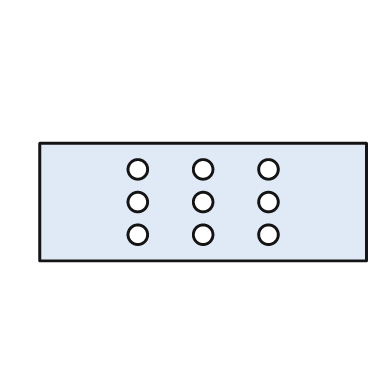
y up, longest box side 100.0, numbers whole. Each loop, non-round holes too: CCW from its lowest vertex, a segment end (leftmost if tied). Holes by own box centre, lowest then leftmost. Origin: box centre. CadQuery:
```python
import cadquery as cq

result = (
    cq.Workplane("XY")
    .moveTo(-50.0, -18.0)
    .lineTo(50.0, -18.0)
    .lineTo(50.0, 18.0)
    .lineTo(-50.0, 18.0)
    .close()
    .moveTo(-20.0, -10.0)
    .circle(3.0)
    .moveTo(0.0, -10.0)
    .circle(3.0)
    .moveTo(20.0, -10.0)
    .circle(3.0)
    .moveTo(-20.0, 0.0)
    .circle(3.0)
    .moveTo(0.0, 0.0)
    .circle(3.0)
    .moveTo(20.0, 0.0)
    .circle(3.0)
    .moveTo(-20.0, 10.0)
    .circle(3.0)
    .moveTo(0.0, 10.0)
    .circle(3.0)
    .moveTo(20.0, 10.0)
    .circle(3.0)
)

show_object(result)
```